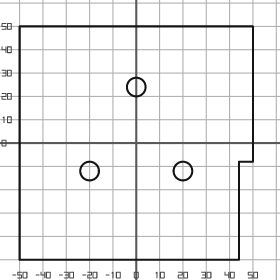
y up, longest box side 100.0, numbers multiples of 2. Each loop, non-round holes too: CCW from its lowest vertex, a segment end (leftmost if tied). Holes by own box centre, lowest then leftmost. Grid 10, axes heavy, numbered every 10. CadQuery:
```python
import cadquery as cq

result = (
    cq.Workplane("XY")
    .moveTo(-50.0, -50.0)
    .lineTo(44.0, -50.0)
    .lineTo(44.0, -8.0)
    .lineTo(50.0, -8.0)
    .lineTo(50.0, 50.0)
    .lineTo(-50.0, 50.0)
    .close()
    .moveTo(-20.0, -12.0)
    .circle(4.0)
    .moveTo(20.0, -12.0)
    .circle(4.0)
    .moveTo(0.0, 24.0)
    .circle(4.0)
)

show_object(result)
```